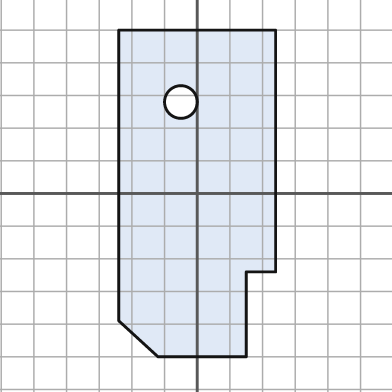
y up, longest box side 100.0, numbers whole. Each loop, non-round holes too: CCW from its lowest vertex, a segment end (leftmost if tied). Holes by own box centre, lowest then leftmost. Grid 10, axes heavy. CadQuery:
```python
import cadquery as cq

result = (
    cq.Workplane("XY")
    .moveTo(-12.0, -50.0)
    .lineTo(15.0, -50.0)
    .lineTo(15.0, -24.0)
    .lineTo(24.0, -24.0)
    .lineTo(24.0, 50.0)
    .lineTo(-24.0, 50.0)
    .lineTo(-24.0, -39.0)
    .close()
    .moveTo(-5.0, 28.0)
    .circle(5.0)
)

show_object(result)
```